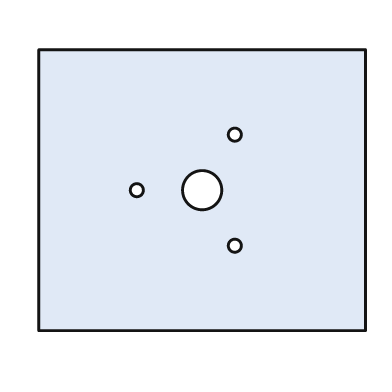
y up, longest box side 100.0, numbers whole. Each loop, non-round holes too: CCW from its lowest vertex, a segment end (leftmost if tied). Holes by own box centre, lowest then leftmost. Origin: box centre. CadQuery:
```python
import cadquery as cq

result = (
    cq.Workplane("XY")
    .moveTo(-50.0, -43.0)
    .lineTo(50.0, -43.0)
    .lineTo(50.0, 43.0)
    .lineTo(-50.0, 43.0)
    .close()
    .moveTo(10.0, -17.0)
    .circle(2.0)
    .moveTo(-20.0, 0.0)
    .circle(2.0)
    .moveTo(0.0, 0.0)
    .circle(6.0)
    .moveTo(10.0, 17.0)
    .circle(2.0)
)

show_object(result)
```